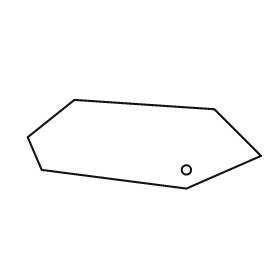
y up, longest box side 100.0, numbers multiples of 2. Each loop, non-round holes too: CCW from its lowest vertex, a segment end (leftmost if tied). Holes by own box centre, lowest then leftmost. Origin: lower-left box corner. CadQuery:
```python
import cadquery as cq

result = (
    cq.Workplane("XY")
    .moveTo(68.0, 0.0)
    .lineTo(100.0, 14.0)
    .lineTo(80.0, 34.0)
    .lineTo(20.0, 38.0)
    .lineTo(0.0, 22.0)
    .lineTo(6.0, 8.0)
    .close()
    .moveTo(68.0, 8.0)
    .circle(2.0)
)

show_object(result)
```